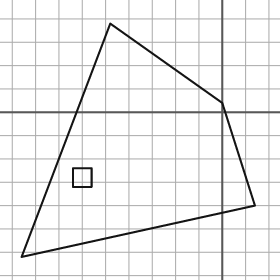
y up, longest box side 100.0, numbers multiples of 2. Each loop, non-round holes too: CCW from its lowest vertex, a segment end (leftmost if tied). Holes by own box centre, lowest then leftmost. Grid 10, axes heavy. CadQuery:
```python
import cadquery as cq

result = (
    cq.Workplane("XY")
    .moveTo(-86.0, -62.0)
    .lineTo(14.0, -40.0)
    .lineTo(0.0, 4.0)
    .lineTo(-48.0, 38.0)
    .close()
    .moveTo(-64.0, -32.0)
    .lineTo(-56.0, -32.0)
    .lineTo(-56.0, -24.0)
    .lineTo(-64.0, -24.0)
    .close()
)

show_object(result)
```